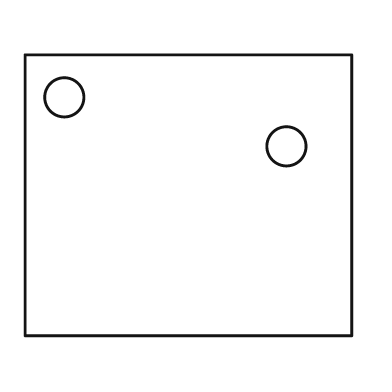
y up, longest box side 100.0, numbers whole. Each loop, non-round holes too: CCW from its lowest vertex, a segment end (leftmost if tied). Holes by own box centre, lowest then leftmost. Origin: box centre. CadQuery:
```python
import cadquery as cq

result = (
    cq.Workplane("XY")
    .moveTo(-50.0, -43.0)
    .lineTo(50.0, -43.0)
    .lineTo(50.0, 43.0)
    .lineTo(-50.0, 43.0)
    .close()
    .moveTo(30.0, 15.0)
    .circle(6.0)
    .moveTo(-38.0, 30.0)
    .circle(6.0)
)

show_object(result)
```